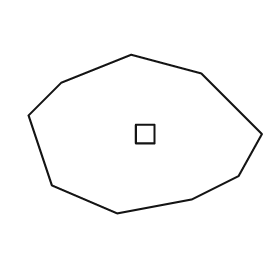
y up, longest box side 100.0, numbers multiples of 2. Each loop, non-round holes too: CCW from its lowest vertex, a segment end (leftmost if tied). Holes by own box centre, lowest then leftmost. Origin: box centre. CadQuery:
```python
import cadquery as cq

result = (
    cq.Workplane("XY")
    .moveTo(-12.0, -34.0)
    .lineTo(20.0, -28.0)
    .lineTo(40.0, -18.0)
    .lineTo(50.0, 0.0)
    .lineTo(24.0, 26.0)
    .lineTo(-6.0, 34.0)
    .lineTo(-36.0, 22.0)
    .lineTo(-50.0, 8.0)
    .lineTo(-40.0, -22.0)
    .close()
    .moveTo(-4.0, -4.0)
    .lineTo(4.0, -4.0)
    .lineTo(4.0, 4.0)
    .lineTo(-4.0, 4.0)
    .close()
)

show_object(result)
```